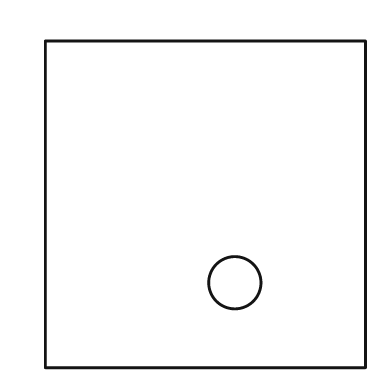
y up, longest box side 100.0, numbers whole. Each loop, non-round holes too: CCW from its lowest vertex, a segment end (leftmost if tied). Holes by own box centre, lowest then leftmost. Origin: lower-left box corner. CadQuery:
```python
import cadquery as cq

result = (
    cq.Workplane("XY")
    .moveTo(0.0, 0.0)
    .lineTo(98.0, 0.0)
    .lineTo(98.0, 100.0)
    .lineTo(0.0, 100.0)
    .close()
    .moveTo(58.0, 26.0)
    .circle(8.0)
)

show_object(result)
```